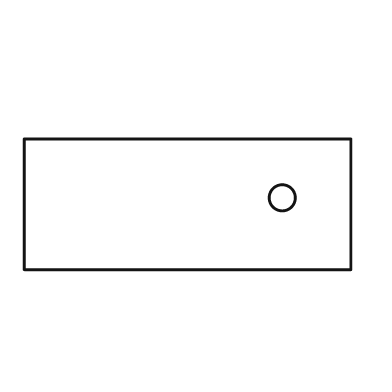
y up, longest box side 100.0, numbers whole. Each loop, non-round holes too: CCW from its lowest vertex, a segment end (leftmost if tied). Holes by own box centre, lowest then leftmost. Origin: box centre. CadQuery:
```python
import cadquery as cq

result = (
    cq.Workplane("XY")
    .moveTo(-50.0, -20.0)
    .lineTo(50.0, -20.0)
    .lineTo(50.0, 20.0)
    .lineTo(-50.0, 20.0)
    .close()
    .moveTo(29.0, 2.0)
    .circle(4.0)
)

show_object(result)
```